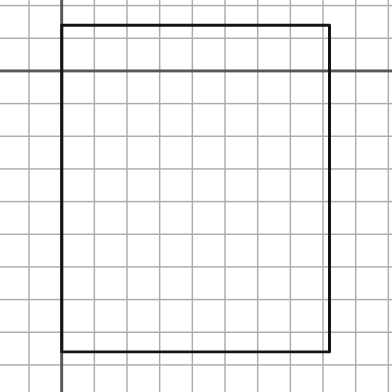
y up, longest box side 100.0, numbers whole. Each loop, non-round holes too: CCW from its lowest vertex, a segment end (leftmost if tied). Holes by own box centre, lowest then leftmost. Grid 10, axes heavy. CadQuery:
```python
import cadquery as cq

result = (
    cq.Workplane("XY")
    .moveTo(0.0, -86.0)
    .lineTo(82.0, -86.0)
    .lineTo(82.0, 14.0)
    .lineTo(0.0, 14.0)
    .close()
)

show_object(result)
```